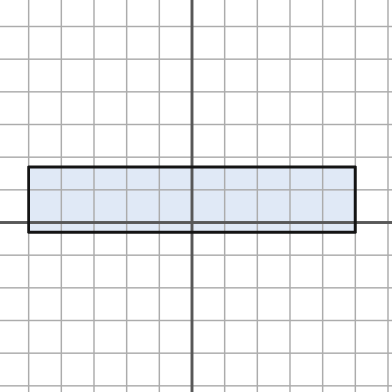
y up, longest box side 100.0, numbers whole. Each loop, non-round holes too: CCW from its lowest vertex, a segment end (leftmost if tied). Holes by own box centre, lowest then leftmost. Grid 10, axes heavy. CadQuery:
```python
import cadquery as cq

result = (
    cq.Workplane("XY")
    .moveTo(-50.0, -3.0)
    .lineTo(50.0, -3.0)
    .lineTo(50.0, 17.0)
    .lineTo(-50.0, 17.0)
    .close()
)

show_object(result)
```